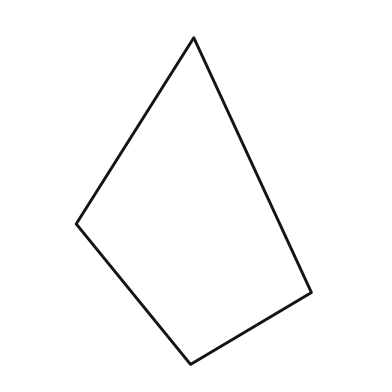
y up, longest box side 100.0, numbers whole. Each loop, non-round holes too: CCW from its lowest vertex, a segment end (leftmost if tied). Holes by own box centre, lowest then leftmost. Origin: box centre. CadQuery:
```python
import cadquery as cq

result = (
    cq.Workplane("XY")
    .moveTo(-1.0, -50.0)
    .lineTo(36.0, -28.0)
    .lineTo(0.0, 50.0)
    .lineTo(-36.0, -7.0)
    .close()
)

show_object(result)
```